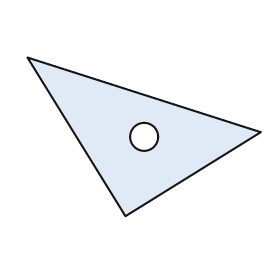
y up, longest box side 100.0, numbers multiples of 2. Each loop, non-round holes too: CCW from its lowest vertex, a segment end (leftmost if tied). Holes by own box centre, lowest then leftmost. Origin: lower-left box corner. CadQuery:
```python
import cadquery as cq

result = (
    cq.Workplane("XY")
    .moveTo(42.0, 0.0)
    .lineTo(100.0, 36.0)
    .lineTo(0.0, 68.0)
    .close()
    .moveTo(50.0, 34.0)
    .circle(6.0)
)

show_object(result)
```